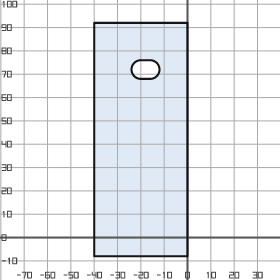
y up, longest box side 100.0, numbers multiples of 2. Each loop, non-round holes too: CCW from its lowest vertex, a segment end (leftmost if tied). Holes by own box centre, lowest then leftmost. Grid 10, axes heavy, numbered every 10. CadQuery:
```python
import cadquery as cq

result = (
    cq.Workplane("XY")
    .moveTo(-40.0, -8.0)
    .lineTo(0.0, -8.0)
    .lineTo(0.0, 92.0)
    .lineTo(-40.0, 92.0)
    .close()
    .moveTo(-20.0, 68.0)
    .lineTo(-16.0, 68.0)
    .threePointArc((-12.0, 72.0), (-16.0, 76.0))
    .lineTo(-20.0, 76.0)
    .threePointArc((-24.0, 72.0), (-20.0, 68.0))
    .close()
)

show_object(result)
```